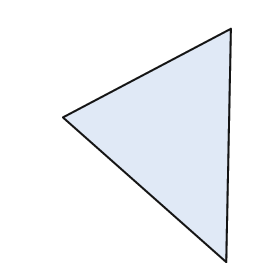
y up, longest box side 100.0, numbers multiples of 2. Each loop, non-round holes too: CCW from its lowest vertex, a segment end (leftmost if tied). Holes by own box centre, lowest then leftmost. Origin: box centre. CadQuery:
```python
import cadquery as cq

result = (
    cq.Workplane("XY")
    .moveTo(34.0, -50.0)
    .lineTo(36.0, 50.0)
    .lineTo(-36.0, 12.0)
    .close()
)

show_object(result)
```